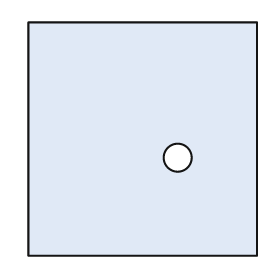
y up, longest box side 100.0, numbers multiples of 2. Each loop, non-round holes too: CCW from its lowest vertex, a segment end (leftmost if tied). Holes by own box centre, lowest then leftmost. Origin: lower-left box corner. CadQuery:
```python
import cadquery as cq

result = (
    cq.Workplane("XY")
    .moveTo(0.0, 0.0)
    .lineTo(98.0, 0.0)
    .lineTo(98.0, 100.0)
    .lineTo(0.0, 100.0)
    .close()
    .moveTo(64.0, 42.0)
    .circle(6.0)
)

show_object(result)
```